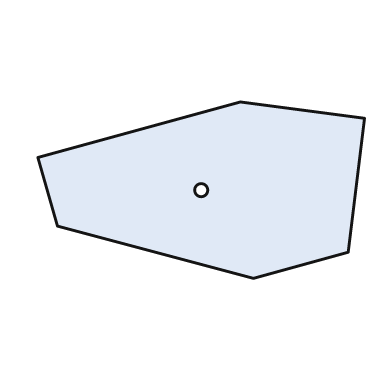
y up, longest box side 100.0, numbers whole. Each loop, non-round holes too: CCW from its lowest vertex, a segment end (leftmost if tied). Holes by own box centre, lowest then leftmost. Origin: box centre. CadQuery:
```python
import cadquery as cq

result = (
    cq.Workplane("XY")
    .moveTo(16.0, -27.0)
    .lineTo(45.0, -19.0)
    .lineTo(50.0, 22.0)
    .lineTo(12.0, 27.0)
    .lineTo(-50.0, 10.0)
    .lineTo(-44.0, -11.0)
    .close()
    .moveTo(0.0, 0.0)
    .circle(2.0)
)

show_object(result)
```